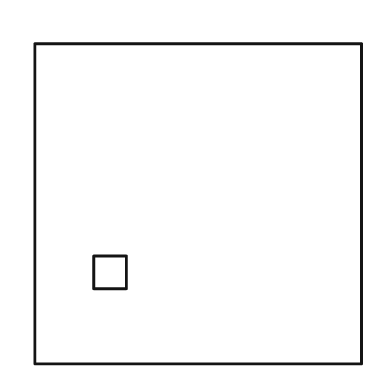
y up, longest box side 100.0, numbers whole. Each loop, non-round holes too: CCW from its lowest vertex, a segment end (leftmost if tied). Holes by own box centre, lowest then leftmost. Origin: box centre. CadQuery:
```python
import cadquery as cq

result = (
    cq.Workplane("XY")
    .moveTo(-50.0, -49.0)
    .lineTo(50.0, -49.0)
    .lineTo(50.0, 49.0)
    .lineTo(-50.0, 49.0)
    .close()
    .moveTo(-32.0, -26.0)
    .lineTo(-22.0, -26.0)
    .lineTo(-22.0, -16.0)
    .lineTo(-32.0, -16.0)
    .close()
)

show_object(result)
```